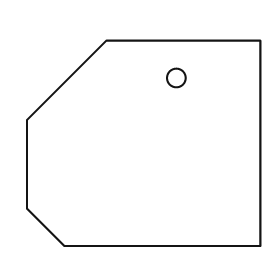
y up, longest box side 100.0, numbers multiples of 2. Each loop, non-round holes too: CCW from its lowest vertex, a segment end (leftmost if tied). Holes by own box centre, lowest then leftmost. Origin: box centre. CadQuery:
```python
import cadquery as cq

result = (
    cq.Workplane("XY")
    .moveTo(-34.0, -44.0)
    .lineTo(50.0, -44.0)
    .lineTo(50.0, 44.0)
    .lineTo(-16.0, 44.0)
    .lineTo(-50.0, 10.0)
    .lineTo(-50.0, -28.0)
    .close()
    .moveTo(14.0, 28.0)
    .circle(4.0)
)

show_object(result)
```